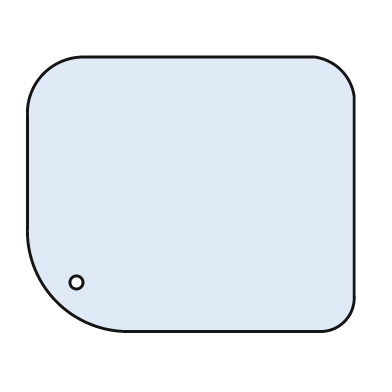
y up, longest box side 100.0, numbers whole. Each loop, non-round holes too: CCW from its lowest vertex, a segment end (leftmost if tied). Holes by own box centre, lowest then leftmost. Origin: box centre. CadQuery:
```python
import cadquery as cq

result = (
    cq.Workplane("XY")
    .moveTo(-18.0, -42.0)
    .lineTo(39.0, -42.0)
    .threePointArc((47.0, -39.0), (50.0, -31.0))
    .lineTo(50.0, 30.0)
    .threePointArc((46.0, 38.0), (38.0, 42.0))
    .lineTo(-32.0, 42.0)
    .threePointArc((-45.0, 37.0), (-50.0, 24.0))
    .lineTo(-50.0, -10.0)
    .threePointArc((-41.0, -33.0), (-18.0, -42.0))
    .close()
    .moveTo(-35.0, -27.0)
    .circle(2.0)
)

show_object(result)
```